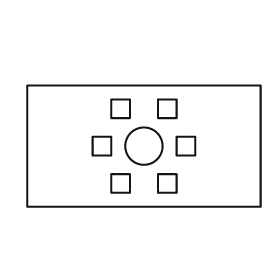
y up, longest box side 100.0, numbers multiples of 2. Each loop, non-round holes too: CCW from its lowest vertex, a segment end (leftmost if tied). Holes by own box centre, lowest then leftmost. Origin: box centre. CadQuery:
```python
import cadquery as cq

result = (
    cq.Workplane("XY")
    .moveTo(-50.0, -26.0)
    .lineTo(50.0, -26.0)
    .lineTo(50.0, 26.0)
    .lineTo(-50.0, 26.0)
    .close()
    .moveTo(-14.0, -20.0)
    .lineTo(-6.0, -20.0)
    .lineTo(-6.0, -12.0)
    .lineTo(-14.0, -12.0)
    .close()
    .moveTo(6.0, -20.0)
    .lineTo(14.0, -20.0)
    .lineTo(14.0, -12.0)
    .lineTo(6.0, -12.0)
    .close()
    .moveTo(-22.0, -4.0)
    .lineTo(-14.0, -4.0)
    .lineTo(-14.0, 4.0)
    .lineTo(-22.0, 4.0)
    .close()
    .moveTo(0.0, 0.0)
    .circle(8.0)
    .moveTo(14.0, -4.0)
    .lineTo(22.0, -4.0)
    .lineTo(22.0, 4.0)
    .lineTo(14.0, 4.0)
    .close()
    .moveTo(-14.0, 12.0)
    .lineTo(-6.0, 12.0)
    .lineTo(-6.0, 20.0)
    .lineTo(-14.0, 20.0)
    .close()
    .moveTo(6.0, 12.0)
    .lineTo(14.0, 12.0)
    .lineTo(14.0, 20.0)
    .lineTo(6.0, 20.0)
    .close()
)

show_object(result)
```